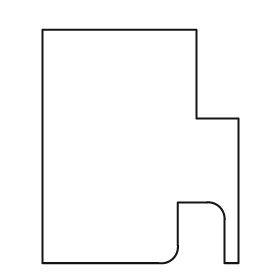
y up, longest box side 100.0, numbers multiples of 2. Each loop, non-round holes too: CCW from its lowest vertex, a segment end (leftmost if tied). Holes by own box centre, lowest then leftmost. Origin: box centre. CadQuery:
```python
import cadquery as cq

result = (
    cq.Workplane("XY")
    .moveTo(-42.0, -50.0)
    .lineTo(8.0, -50.0)
    .threePointArc((14.0, -48.0), (16.0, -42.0))
    .lineTo(16.0, -24.0)
    .lineTo(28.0, -24.0)
    .threePointArc((34.0, -26.0), (36.0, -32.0))
    .lineTo(36.0, -50.0)
    .lineTo(42.0, -50.0)
    .lineTo(42.0, 12.0)
    .lineTo(24.0, 12.0)
    .lineTo(24.0, 50.0)
    .lineTo(-42.0, 50.0)
    .close()
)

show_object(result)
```